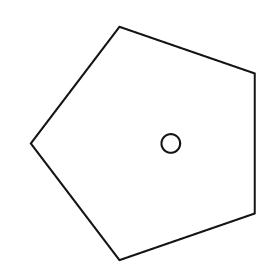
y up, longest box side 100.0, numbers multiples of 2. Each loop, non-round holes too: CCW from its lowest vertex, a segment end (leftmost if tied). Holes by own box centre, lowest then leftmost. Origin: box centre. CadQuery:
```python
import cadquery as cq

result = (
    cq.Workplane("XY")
    .moveTo(-10.0, -50.0)
    .lineTo(48.0, -30.0)
    .lineTo(48.0, 30.0)
    .lineTo(-10.0, 50.0)
    .lineTo(-48.0, 0.0)
    .close()
    .moveTo(12.0, 0.0)
    .circle(4.0)
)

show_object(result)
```